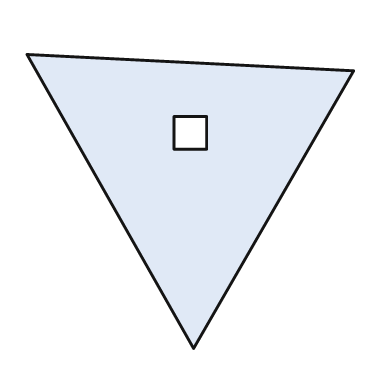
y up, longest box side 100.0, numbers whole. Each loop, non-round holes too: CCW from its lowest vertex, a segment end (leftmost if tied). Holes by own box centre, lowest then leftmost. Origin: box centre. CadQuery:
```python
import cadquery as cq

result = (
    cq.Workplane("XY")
    .moveTo(1.0, -45.0)
    .lineTo(50.0, 40.0)
    .lineTo(-50.0, 45.0)
    .close()
    .moveTo(-5.0, 16.0)
    .lineTo(5.0, 16.0)
    .lineTo(5.0, 26.0)
    .lineTo(-5.0, 26.0)
    .close()
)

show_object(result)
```